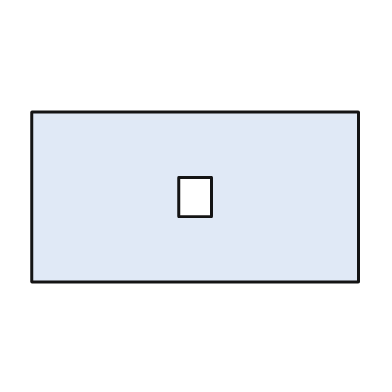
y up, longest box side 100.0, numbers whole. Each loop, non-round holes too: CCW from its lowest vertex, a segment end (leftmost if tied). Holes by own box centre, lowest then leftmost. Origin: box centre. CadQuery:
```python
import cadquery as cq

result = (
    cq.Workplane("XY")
    .moveTo(-50.0, -26.0)
    .lineTo(50.0, -26.0)
    .lineTo(50.0, 26.0)
    .lineTo(-50.0, 26.0)
    .close()
    .moveTo(-5.0, -6.0)
    .lineTo(5.0, -6.0)
    .lineTo(5.0, 6.0)
    .lineTo(-5.0, 6.0)
    .close()
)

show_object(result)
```